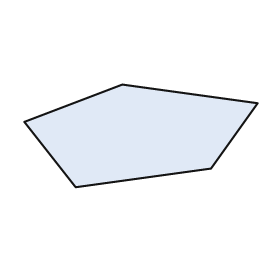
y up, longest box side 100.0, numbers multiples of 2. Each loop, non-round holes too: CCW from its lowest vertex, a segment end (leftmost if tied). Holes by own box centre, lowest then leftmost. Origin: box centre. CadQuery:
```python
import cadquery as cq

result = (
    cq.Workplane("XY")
    .moveTo(-28.0, -22.0)
    .lineTo(30.0, -14.0)
    .lineTo(50.0, 14.0)
    .lineTo(-8.0, 22.0)
    .lineTo(-50.0, 6.0)
    .close()
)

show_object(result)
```